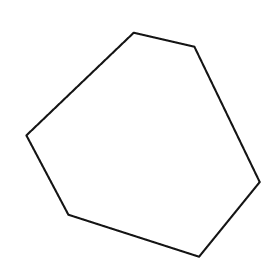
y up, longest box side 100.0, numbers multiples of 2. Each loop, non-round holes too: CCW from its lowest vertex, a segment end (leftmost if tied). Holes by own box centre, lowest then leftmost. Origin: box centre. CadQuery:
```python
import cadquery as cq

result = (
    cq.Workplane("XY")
    .moveTo(24.0, -48.0)
    .lineTo(50.0, -16.0)
    .lineTo(22.0, 42.0)
    .lineTo(-4.0, 48.0)
    .lineTo(-50.0, 4.0)
    .lineTo(-32.0, -30.0)
    .close()
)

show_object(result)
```